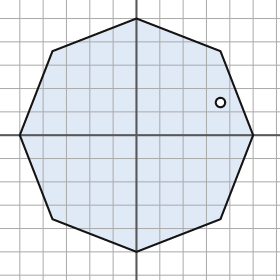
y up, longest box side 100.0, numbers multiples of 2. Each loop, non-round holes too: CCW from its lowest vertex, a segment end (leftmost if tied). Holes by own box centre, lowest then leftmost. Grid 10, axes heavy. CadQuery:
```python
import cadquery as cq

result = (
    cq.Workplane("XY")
    .moveTo(0.0, -50.0)
    .lineTo(36.0, -36.0)
    .lineTo(50.0, 0.0)
    .lineTo(36.0, 36.0)
    .lineTo(0.0, 50.0)
    .lineTo(-36.0, 36.0)
    .lineTo(-50.0, 0.0)
    .lineTo(-36.0, -36.0)
    .close()
    .moveTo(36.0, 14.0)
    .circle(2.0)
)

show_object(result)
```